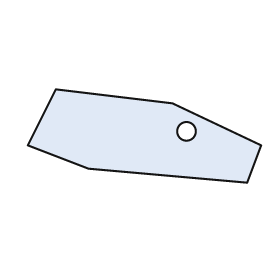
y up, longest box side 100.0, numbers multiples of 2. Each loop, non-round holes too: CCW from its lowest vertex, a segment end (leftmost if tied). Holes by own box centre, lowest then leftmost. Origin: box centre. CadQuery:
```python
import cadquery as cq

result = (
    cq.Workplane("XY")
    .moveTo(44.0, -20.0)
    .lineTo(50.0, -4.0)
    .lineTo(12.0, 14.0)
    .lineTo(-38.0, 20.0)
    .lineTo(-50.0, -4.0)
    .lineTo(-24.0, -14.0)
    .close()
    .moveTo(18.0, 2.0)
    .circle(4.0)
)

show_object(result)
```